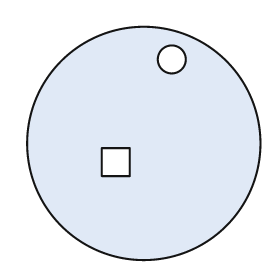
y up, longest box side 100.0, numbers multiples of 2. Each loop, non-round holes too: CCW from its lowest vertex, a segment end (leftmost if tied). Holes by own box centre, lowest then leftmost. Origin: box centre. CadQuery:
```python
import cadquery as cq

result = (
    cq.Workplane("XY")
    .moveTo(0.0, 0.0)
    .circle(50.0)
    .moveTo(-18.0, -14.0)
    .lineTo(-6.0, -14.0)
    .lineTo(-6.0, -2.0)
    .lineTo(-18.0, -2.0)
    .close()
    .moveTo(12.0, 36.0)
    .circle(6.0)
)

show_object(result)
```